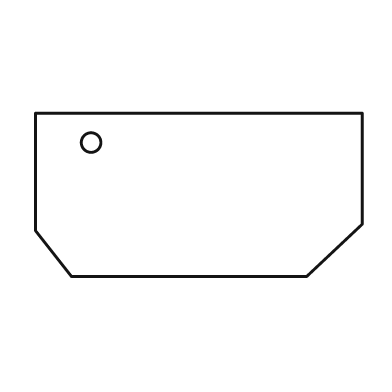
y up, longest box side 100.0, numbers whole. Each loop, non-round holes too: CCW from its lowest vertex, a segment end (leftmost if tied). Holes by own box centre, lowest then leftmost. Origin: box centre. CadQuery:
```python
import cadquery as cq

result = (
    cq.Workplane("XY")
    .moveTo(-39.0, -25.0)
    .lineTo(33.0, -25.0)
    .lineTo(50.0, -9.0)
    .lineTo(50.0, 25.0)
    .lineTo(-50.0, 25.0)
    .lineTo(-50.0, -11.0)
    .close()
    .moveTo(-33.0, 16.0)
    .circle(3.0)
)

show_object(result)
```